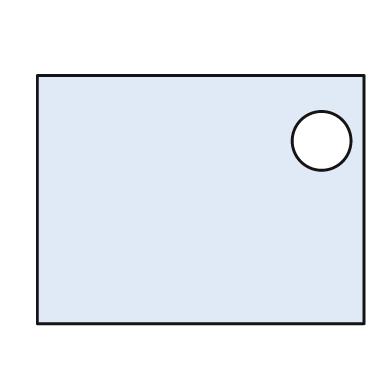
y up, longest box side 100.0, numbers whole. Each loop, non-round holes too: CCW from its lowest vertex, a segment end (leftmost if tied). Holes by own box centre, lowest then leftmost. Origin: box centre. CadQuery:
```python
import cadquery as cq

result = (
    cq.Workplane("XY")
    .moveTo(-50.0, -38.0)
    .lineTo(50.0, -38.0)
    .lineTo(50.0, 38.0)
    .lineTo(-50.0, 38.0)
    .close()
    .moveTo(37.0, 18.0)
    .circle(9.0)
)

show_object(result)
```